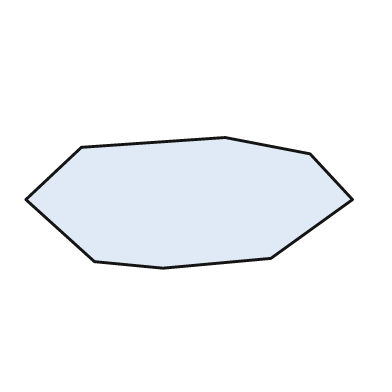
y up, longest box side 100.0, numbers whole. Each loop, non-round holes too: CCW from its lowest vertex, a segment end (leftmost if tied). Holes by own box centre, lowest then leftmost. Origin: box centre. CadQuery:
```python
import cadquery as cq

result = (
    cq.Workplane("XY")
    .moveTo(-8.0, -20.0)
    .lineTo(25.0, -17.0)
    .lineTo(50.0, 1.0)
    .lineTo(37.0, 15.0)
    .lineTo(11.0, 20.0)
    .lineTo(-33.0, 17.0)
    .lineTo(-50.0, 1.0)
    .lineTo(-29.0, -18.0)
    .close()
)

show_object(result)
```